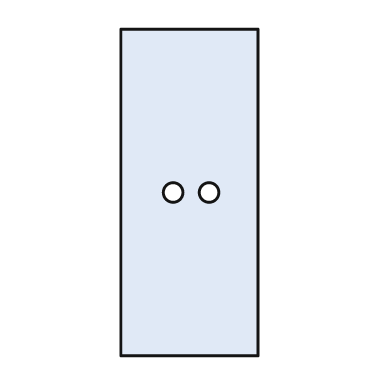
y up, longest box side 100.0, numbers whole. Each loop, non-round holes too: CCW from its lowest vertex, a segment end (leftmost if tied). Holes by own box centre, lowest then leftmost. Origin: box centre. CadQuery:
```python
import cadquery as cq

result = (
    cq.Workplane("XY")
    .moveTo(-21.0, -50.0)
    .lineTo(21.0, -50.0)
    .lineTo(21.0, 50.0)
    .lineTo(-21.0, 50.0)
    .close()
    .moveTo(-5.0, 0.0)
    .circle(3.0)
    .moveTo(6.0, 0.0)
    .circle(3.0)
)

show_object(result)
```